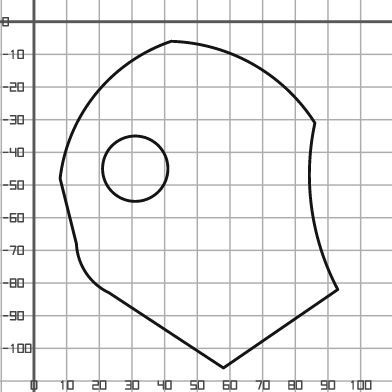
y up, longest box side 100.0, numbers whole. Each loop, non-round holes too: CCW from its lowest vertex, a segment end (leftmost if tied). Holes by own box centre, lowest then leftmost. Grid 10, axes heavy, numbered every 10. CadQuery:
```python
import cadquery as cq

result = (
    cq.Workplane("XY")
    .moveTo(58.0, -106.0)
    .lineTo(93.0, -82.0)
    .threePointArc((85.0, -57.0), (86.0, -31.0))
    .threePointArc((67.0, -13.0), (42.0, -6.0))
    .threePointArc((19.0, -22.0), (8.0, -48.0))
    .lineTo(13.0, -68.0)
    .threePointArc((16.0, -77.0), (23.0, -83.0))
    .close()
    .moveTo(31.0, -45.0)
    .circle(10.0)
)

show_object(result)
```